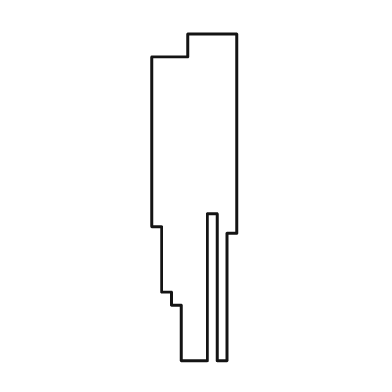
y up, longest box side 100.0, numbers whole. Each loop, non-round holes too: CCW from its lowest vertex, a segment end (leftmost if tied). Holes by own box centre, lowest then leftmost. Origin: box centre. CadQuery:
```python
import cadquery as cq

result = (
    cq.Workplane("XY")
    .moveTo(-4.0, -50.0)
    .lineTo(4.0, -50.0)
    .lineTo(4.0, -5.0)
    .lineTo(7.0, -5.0)
    .lineTo(7.0, -50.0)
    .lineTo(10.0, -50.0)
    .lineTo(10.0, -11.0)
    .lineTo(13.0, -11.0)
    .lineTo(13.0, 50.0)
    .lineTo(-2.0, 50.0)
    .lineTo(-2.0, 43.0)
    .lineTo(-13.0, 43.0)
    .lineTo(-13.0, -9.0)
    .lineTo(-10.0, -9.0)
    .lineTo(-10.0, -29.0)
    .lineTo(-7.0, -29.0)
    .lineTo(-7.0, -33.0)
    .lineTo(-4.0, -33.0)
    .close()
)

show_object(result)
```